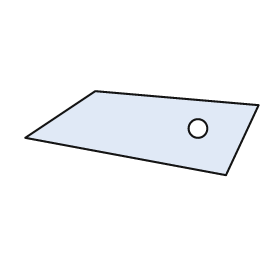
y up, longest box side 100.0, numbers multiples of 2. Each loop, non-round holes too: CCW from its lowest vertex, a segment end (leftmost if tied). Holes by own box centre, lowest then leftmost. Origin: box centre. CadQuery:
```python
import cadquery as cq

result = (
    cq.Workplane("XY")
    .moveTo(36.0, -18.0)
    .lineTo(50.0, 12.0)
    .lineTo(-20.0, 18.0)
    .lineTo(-50.0, -2.0)
    .close()
    .moveTo(24.0, 2.0)
    .circle(4.0)
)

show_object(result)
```